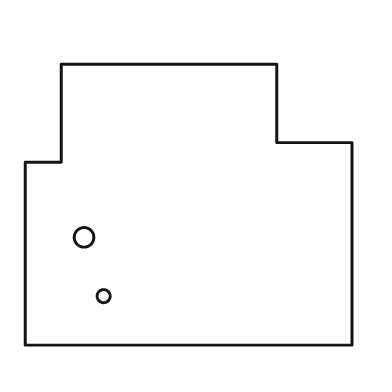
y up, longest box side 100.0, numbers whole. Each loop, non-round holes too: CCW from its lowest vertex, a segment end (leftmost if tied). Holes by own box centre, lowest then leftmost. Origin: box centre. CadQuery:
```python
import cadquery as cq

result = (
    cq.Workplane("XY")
    .moveTo(-50.0, -43.0)
    .lineTo(50.0, -43.0)
    .lineTo(50.0, 19.0)
    .lineTo(27.0, 19.0)
    .lineTo(27.0, 43.0)
    .lineTo(-39.0, 43.0)
    .lineTo(-39.0, 13.0)
    .lineTo(-50.0, 13.0)
    .close()
    .moveTo(-26.0, -28.0)
    .circle(2.0)
    .moveTo(-32.0, -10.0)
    .circle(3.0)
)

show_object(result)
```